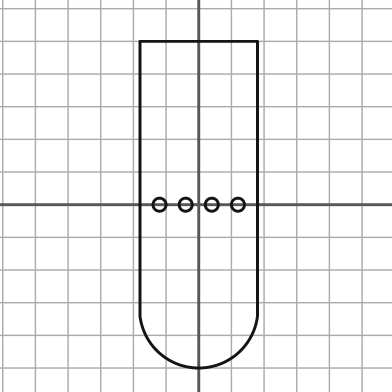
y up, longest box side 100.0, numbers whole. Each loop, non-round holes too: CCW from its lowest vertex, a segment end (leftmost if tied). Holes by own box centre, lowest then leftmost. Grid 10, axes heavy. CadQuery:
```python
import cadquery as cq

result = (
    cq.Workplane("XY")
    .moveTo(-18.0, -34.0)
    .threePointArc((0.0, -50.0), (18.0, -34.0))
    .lineTo(18.0, 50.0)
    .lineTo(-18.0, 50.0)
    .close()
    .moveTo(-12.0, 0.0)
    .circle(2.0)
    .moveTo(-4.0, 0.0)
    .circle(2.0)
    .moveTo(4.0, 0.0)
    .circle(2.0)
    .moveTo(12.0, 0.0)
    .circle(2.0)
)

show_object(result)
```